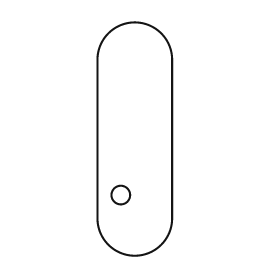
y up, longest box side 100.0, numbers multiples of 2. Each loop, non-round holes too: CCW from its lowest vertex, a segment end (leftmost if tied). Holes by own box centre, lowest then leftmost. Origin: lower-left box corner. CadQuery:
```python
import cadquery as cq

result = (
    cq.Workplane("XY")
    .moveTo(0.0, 16.0)
    .threePointArc((16.0, 0.0), (32.0, 16.0))
    .lineTo(32.0, 84.0)
    .threePointArc((16.0, 100.0), (0.0, 84.0))
    .close()
    .moveTo(10.0, 26.0)
    .circle(4.0)
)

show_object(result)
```